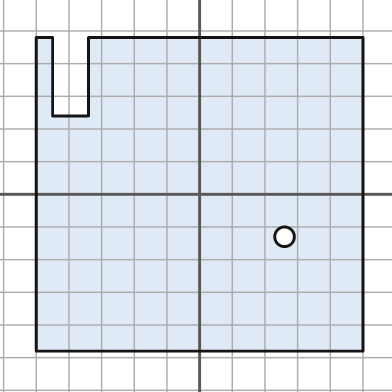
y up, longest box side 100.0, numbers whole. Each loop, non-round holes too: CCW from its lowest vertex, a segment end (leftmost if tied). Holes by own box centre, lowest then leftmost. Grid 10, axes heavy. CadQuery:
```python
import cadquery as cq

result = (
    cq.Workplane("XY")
    .moveTo(-50.0, -48.0)
    .lineTo(50.0, -48.0)
    .lineTo(50.0, 48.0)
    .lineTo(-34.0, 48.0)
    .lineTo(-34.0, 24.0)
    .lineTo(-45.0, 24.0)
    .lineTo(-45.0, 48.0)
    .lineTo(-50.0, 48.0)
    .close()
    .moveTo(26.0, -13.0)
    .circle(3.0)
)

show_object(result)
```